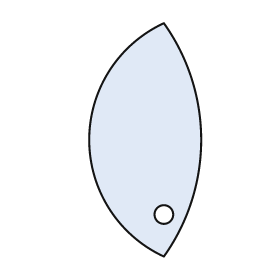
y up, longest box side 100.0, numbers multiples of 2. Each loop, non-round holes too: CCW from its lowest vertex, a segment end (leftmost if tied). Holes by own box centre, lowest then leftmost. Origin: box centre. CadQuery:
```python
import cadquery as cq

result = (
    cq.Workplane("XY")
    .moveTo(8.0, -50.0)
    .threePointArc((24.0, 0.0), (8.0, 50.0))
    .threePointArc((-24.0, 0.0), (8.0, -50.0))
    .close()
    .moveTo(8.0, -32.0)
    .circle(4.0)
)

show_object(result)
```